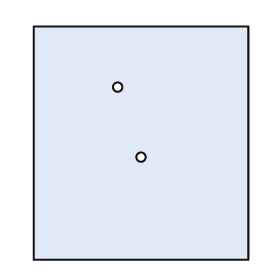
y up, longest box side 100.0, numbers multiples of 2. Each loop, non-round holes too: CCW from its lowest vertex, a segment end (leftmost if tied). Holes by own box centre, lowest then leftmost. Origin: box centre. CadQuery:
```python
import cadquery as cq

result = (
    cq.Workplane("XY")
    .moveTo(-46.0, -50.0)
    .lineTo(46.0, -50.0)
    .lineTo(46.0, 50.0)
    .lineTo(-46.0, 50.0)
    .close()
    .moveTo(0.0, -6.0)
    .circle(2.0)
    .moveTo(-10.0, 24.0)
    .circle(2.0)
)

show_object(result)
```